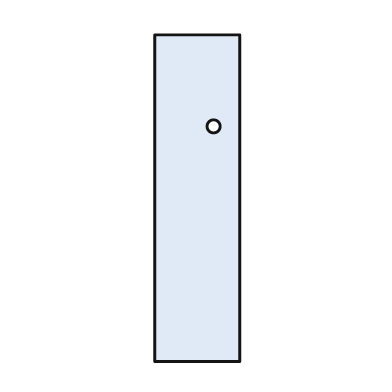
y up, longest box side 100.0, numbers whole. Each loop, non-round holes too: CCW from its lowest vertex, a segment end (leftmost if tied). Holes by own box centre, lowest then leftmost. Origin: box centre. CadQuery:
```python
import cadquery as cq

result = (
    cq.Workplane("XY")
    .moveTo(-13.0, -50.0)
    .lineTo(13.0, -50.0)
    .lineTo(13.0, 50.0)
    .lineTo(-13.0, 50.0)
    .close()
    .moveTo(5.0, 22.0)
    .circle(2.0)
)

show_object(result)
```